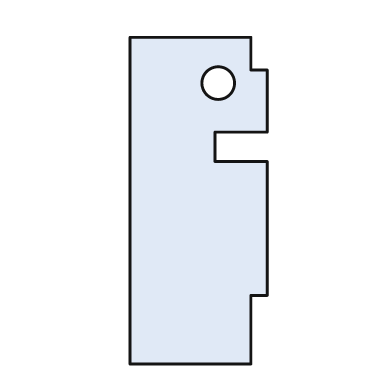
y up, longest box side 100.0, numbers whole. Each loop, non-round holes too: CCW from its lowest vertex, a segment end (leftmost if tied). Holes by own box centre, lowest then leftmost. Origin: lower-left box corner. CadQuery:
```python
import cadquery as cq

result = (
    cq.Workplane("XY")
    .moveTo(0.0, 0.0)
    .lineTo(37.0, 0.0)
    .lineTo(37.0, 21.0)
    .lineTo(42.0, 21.0)
    .lineTo(42.0, 62.0)
    .lineTo(26.0, 62.0)
    .lineTo(26.0, 71.0)
    .lineTo(42.0, 71.0)
    .lineTo(42.0, 90.0)
    .lineTo(37.0, 90.0)
    .lineTo(37.0, 100.0)
    .lineTo(0.0, 100.0)
    .close()
    .moveTo(27.0, 86.0)
    .circle(5.0)
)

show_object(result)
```